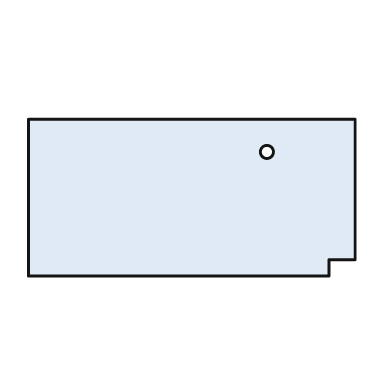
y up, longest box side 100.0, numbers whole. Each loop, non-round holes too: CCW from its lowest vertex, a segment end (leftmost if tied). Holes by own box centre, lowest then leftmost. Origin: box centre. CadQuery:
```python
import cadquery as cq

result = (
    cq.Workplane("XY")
    .moveTo(-50.0, -24.0)
    .lineTo(42.0, -24.0)
    .lineTo(42.0, -19.0)
    .lineTo(50.0, -19.0)
    .lineTo(50.0, 24.0)
    .lineTo(-50.0, 24.0)
    .close()
    .moveTo(23.0, 14.0)
    .circle(2.0)
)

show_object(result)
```